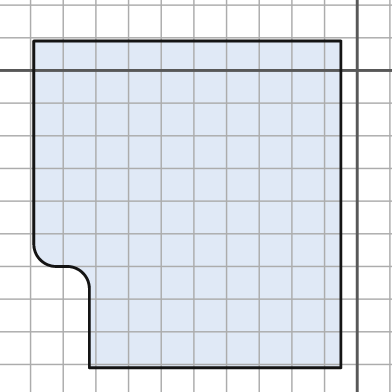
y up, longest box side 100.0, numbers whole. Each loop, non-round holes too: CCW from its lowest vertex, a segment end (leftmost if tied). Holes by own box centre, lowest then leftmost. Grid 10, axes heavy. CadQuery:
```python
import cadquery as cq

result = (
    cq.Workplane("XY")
    .moveTo(-82.0, -91.0)
    .lineTo(-5.0, -91.0)
    .lineTo(-5.0, 9.0)
    .lineTo(-99.0, 9.0)
    .lineTo(-99.0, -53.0)
    .threePointArc((-97.0, -58.0), (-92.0, -60.0))
    .lineTo(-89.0, -60.0)
    .threePointArc((-84.0, -62.0), (-82.0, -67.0))
    .close()
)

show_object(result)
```